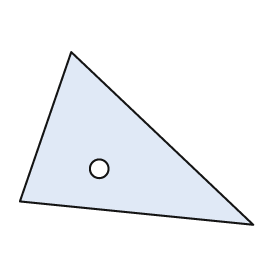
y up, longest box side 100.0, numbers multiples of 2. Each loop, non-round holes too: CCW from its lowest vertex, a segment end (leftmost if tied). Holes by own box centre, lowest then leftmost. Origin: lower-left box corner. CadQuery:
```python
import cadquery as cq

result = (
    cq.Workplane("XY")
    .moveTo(100.0, 0.0)
    .lineTo(22.0, 74.0)
    .lineTo(0.0, 10.0)
    .close()
    .moveTo(34.0, 24.0)
    .circle(4.0)
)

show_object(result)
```